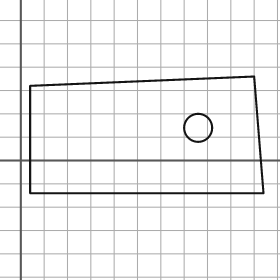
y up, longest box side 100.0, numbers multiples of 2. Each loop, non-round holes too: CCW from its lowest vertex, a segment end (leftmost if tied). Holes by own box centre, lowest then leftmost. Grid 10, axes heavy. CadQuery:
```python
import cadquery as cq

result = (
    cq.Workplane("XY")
    .moveTo(4.0, -14.0)
    .lineTo(104.0, -14.0)
    .lineTo(100.0, 36.0)
    .lineTo(4.0, 32.0)
    .close()
    .moveTo(76.0, 14.0)
    .circle(6.0)
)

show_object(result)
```